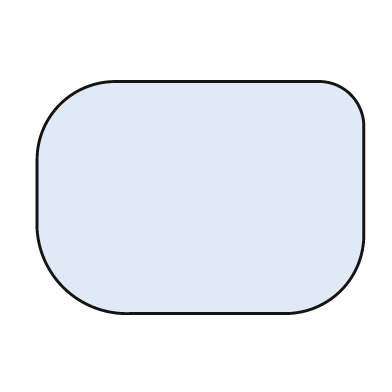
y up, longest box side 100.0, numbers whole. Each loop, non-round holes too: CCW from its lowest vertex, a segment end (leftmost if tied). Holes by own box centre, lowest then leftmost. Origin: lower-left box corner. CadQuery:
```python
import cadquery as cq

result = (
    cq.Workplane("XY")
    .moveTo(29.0, 0.0)
    .lineTo(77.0, 0.0)
    .threePointArc((93.0, 7.0), (100.0, 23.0))
    .lineTo(100.0, 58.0)
    .threePointArc((96.0, 67.0), (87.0, 71.0))
    .lineTo(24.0, 71.0)
    .threePointArc((7.0, 64.0), (0.0, 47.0))
    .lineTo(0.0, 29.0)
    .threePointArc((8.0, 8.0), (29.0, 0.0))
    .close()
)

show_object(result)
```